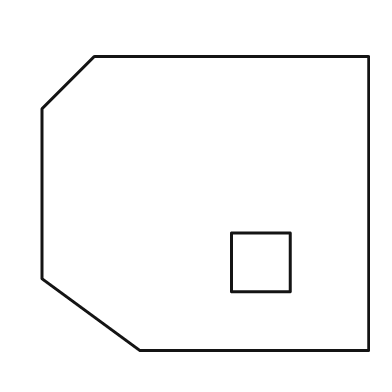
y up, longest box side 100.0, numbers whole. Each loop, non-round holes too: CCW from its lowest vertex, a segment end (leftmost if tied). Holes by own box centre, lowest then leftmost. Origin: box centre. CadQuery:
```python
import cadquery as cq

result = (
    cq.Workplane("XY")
    .moveTo(-20.0, -45.0)
    .lineTo(50.0, -45.0)
    .lineTo(50.0, 45.0)
    .lineTo(-34.0, 45.0)
    .lineTo(-50.0, 29.0)
    .lineTo(-50.0, -23.0)
    .close()
    .moveTo(8.0, -27.0)
    .lineTo(26.0, -27.0)
    .lineTo(26.0, -9.0)
    .lineTo(8.0, -9.0)
    .close()
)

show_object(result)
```